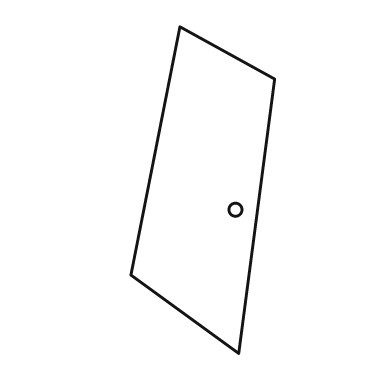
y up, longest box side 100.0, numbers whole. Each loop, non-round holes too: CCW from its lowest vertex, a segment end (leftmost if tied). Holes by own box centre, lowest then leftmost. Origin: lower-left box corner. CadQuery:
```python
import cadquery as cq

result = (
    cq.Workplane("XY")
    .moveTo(33.0, 0.0)
    .lineTo(44.0, 84.0)
    .lineTo(15.0, 100.0)
    .lineTo(0.0, 24.0)
    .close()
    .moveTo(32.0, 44.0)
    .circle(2.0)
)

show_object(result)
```